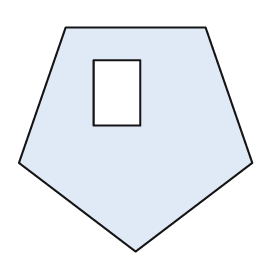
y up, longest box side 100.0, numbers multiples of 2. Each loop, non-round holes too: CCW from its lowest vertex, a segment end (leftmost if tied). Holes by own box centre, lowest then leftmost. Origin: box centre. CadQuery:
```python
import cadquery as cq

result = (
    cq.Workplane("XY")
    .moveTo(0.0, -48.0)
    .lineTo(50.0, -10.0)
    .lineTo(30.0, 48.0)
    .lineTo(-30.0, 48.0)
    .lineTo(-50.0, -10.0)
    .close()
    .moveTo(-18.0, 6.0)
    .lineTo(2.0, 6.0)
    .lineTo(2.0, 34.0)
    .lineTo(-18.0, 34.0)
    .close()
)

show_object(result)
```